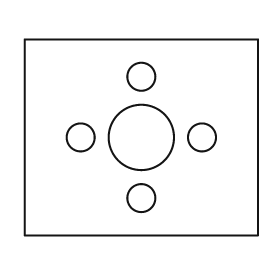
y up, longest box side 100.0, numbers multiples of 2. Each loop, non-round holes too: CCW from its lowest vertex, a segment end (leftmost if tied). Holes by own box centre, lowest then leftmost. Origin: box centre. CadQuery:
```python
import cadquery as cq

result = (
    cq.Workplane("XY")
    .moveTo(-50.0, -42.0)
    .lineTo(50.0, -42.0)
    .lineTo(50.0, 42.0)
    .lineTo(-50.0, 42.0)
    .close()
    .moveTo(0.0, -26.0)
    .circle(6.0)
    .moveTo(-26.0, 0.0)
    .circle(6.0)
    .moveTo(0.0, 0.0)
    .circle(14.0)
    .moveTo(26.0, 0.0)
    .circle(6.0)
    .moveTo(0.0, 26.0)
    .circle(6.0)
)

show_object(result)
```